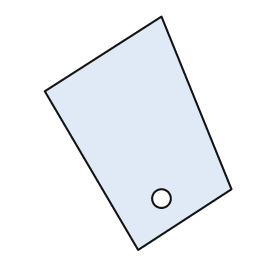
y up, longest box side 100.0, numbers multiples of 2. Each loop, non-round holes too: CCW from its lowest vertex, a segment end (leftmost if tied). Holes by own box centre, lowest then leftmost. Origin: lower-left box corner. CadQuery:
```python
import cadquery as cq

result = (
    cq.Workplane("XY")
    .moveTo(40.0, 0.0)
    .lineTo(80.0, 26.0)
    .lineTo(50.0, 100.0)
    .lineTo(0.0, 68.0)
    .close()
    .moveTo(50.0, 22.0)
    .circle(4.0)
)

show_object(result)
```